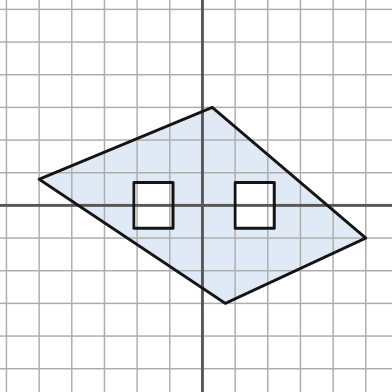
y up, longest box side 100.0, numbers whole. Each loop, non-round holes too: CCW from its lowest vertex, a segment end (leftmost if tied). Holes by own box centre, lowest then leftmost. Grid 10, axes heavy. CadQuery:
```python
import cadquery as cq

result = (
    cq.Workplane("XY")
    .moveTo(7.0, -30.0)
    .lineTo(50.0, -10.0)
    .lineTo(3.0, 30.0)
    .lineTo(-50.0, 8.0)
    .close()
    .moveTo(-21.0, -7.0)
    .lineTo(-9.0, -7.0)
    .lineTo(-9.0, 7.0)
    .lineTo(-21.0, 7.0)
    .close()
    .moveTo(10.0, -7.0)
    .lineTo(22.0, -7.0)
    .lineTo(22.0, 7.0)
    .lineTo(10.0, 7.0)
    .close()
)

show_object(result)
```